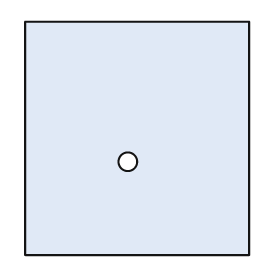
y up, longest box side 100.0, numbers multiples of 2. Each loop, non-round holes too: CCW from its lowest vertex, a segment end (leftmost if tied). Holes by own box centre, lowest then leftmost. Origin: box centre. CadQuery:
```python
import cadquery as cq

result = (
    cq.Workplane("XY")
    .moveTo(-48.0, -50.0)
    .lineTo(48.0, -50.0)
    .lineTo(48.0, 50.0)
    .lineTo(-48.0, 50.0)
    .close()
    .moveTo(-4.0, -10.0)
    .circle(4.0)
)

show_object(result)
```